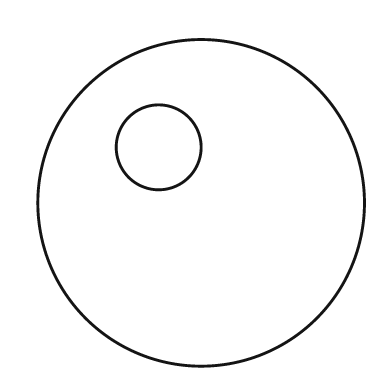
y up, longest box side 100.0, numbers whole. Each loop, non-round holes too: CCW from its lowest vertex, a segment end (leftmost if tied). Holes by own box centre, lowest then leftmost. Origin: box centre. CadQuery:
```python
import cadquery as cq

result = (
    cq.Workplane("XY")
    .moveTo(0.0, 0.0)
    .circle(50.0)
    .moveTo(-13.0, 17.0)
    .circle(13.0)
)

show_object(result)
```